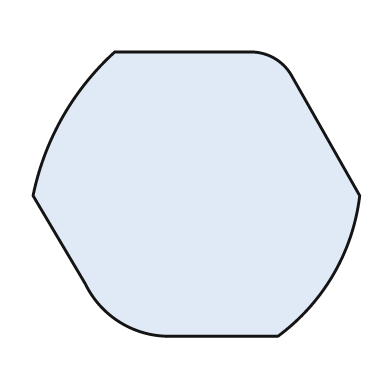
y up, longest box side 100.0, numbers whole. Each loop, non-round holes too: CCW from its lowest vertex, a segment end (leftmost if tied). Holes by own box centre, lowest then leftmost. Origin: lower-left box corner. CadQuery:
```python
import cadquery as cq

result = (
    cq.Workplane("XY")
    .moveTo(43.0, 0.0)
    .lineTo(75.0, 0.0)
    .threePointArc((92.0, 19.0), (100.0, 43.0))
    .lineTo(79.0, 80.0)
    .threePointArc((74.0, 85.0), (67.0, 87.0))
    .lineTo(25.0, 87.0)
    .threePointArc((9.0, 67.0), (0.0, 43.0))
    .lineTo(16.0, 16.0)
    .threePointArc((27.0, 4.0), (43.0, 0.0))
    .close()
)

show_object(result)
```